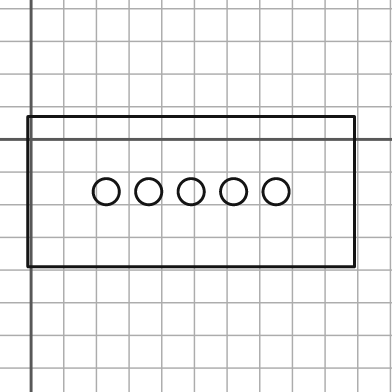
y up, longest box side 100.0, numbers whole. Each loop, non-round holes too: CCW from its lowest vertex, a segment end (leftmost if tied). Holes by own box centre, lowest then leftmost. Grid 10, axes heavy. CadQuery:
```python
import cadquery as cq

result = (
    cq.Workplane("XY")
    .moveTo(-1.0, -39.0)
    .lineTo(99.0, -39.0)
    .lineTo(99.0, 7.0)
    .lineTo(-1.0, 7.0)
    .close()
    .moveTo(23.0, -16.0)
    .circle(4.0)
    .moveTo(36.0, -16.0)
    .circle(4.0)
    .moveTo(49.0, -16.0)
    .circle(4.0)
    .moveTo(62.0, -16.0)
    .circle(4.0)
    .moveTo(75.0, -16.0)
    .circle(4.0)
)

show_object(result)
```